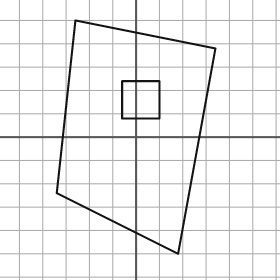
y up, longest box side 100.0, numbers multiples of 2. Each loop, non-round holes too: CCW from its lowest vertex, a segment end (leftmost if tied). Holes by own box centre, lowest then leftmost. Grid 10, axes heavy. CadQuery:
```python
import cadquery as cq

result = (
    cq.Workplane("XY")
    .moveTo(18.0, -50.0)
    .lineTo(34.0, 38.0)
    .lineTo(-26.0, 50.0)
    .lineTo(-34.0, -24.0)
    .close()
    .moveTo(-6.0, 8.0)
    .lineTo(10.0, 8.0)
    .lineTo(10.0, 24.0)
    .lineTo(-6.0, 24.0)
    .close()
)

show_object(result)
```